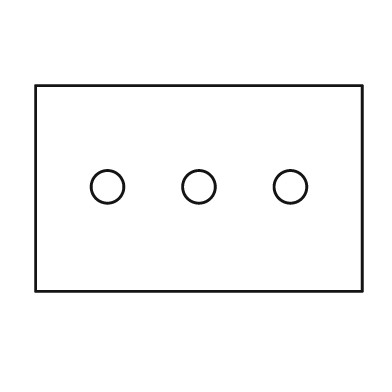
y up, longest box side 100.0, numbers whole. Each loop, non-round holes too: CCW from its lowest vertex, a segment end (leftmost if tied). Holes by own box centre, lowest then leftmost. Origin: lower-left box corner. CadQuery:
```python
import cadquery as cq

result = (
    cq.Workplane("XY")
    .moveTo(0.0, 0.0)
    .lineTo(100.0, 0.0)
    .lineTo(100.0, 63.0)
    .lineTo(0.0, 63.0)
    .close()
    .moveTo(22.0, 32.0)
    .circle(5.0)
    .moveTo(50.0, 32.0)
    .circle(5.0)
    .moveTo(78.0, 32.0)
    .circle(5.0)
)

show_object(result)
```